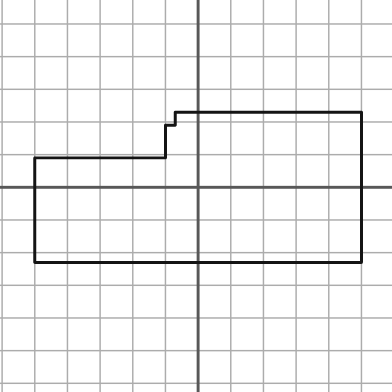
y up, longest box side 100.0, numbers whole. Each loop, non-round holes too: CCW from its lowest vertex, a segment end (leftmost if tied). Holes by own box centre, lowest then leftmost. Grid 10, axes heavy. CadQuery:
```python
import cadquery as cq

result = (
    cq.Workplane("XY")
    .moveTo(-50.0, -23.0)
    .lineTo(50.0, -23.0)
    .lineTo(50.0, 23.0)
    .lineTo(-7.0, 23.0)
    .lineTo(-7.0, 19.0)
    .lineTo(-10.0, 19.0)
    .lineTo(-10.0, 9.0)
    .lineTo(-50.0, 9.0)
    .close()
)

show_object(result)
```